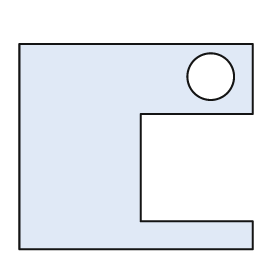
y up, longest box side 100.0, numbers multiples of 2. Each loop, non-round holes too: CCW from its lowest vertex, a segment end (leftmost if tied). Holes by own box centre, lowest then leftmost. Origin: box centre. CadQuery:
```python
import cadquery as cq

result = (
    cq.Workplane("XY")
    .moveTo(-50.0, -44.0)
    .lineTo(50.0, -44.0)
    .lineTo(50.0, -32.0)
    .lineTo(2.0, -32.0)
    .lineTo(2.0, 14.0)
    .lineTo(50.0, 14.0)
    .lineTo(50.0, 44.0)
    .lineTo(-50.0, 44.0)
    .close()
    .moveTo(32.0, 30.0)
    .circle(10.0)
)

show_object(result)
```